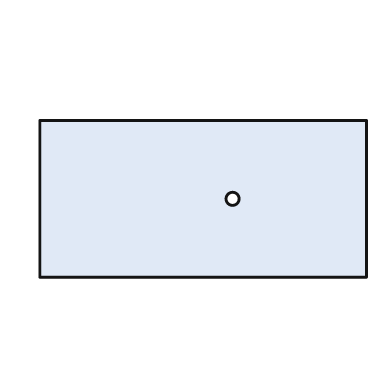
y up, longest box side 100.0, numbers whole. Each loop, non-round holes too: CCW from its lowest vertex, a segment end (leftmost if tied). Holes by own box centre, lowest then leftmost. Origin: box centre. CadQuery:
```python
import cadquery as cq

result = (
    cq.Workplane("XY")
    .moveTo(-50.0, -24.0)
    .lineTo(50.0, -24.0)
    .lineTo(50.0, 24.0)
    .lineTo(-50.0, 24.0)
    .close()
    .moveTo(9.0, 0.0)
    .circle(2.0)
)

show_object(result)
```